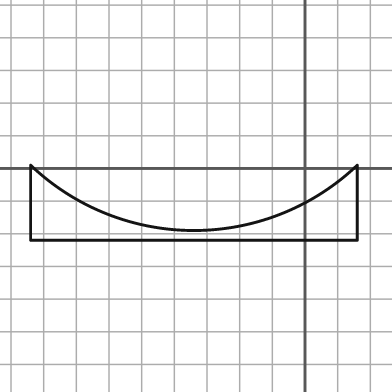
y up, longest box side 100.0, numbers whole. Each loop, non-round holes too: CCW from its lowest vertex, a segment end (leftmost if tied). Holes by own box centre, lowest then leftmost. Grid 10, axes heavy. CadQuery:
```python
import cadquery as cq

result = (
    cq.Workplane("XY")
    .moveTo(-84.0, -22.0)
    .lineTo(16.0, -22.0)
    .lineTo(16.0, 1.0)
    .threePointArc((-34.0, -19.0), (-84.0, 1.0))
    .close()
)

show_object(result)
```